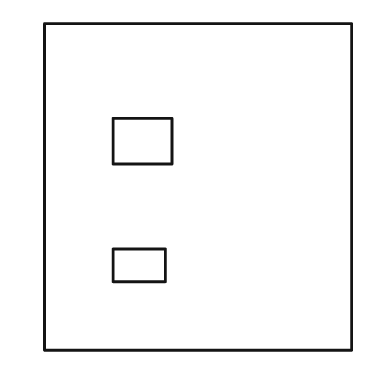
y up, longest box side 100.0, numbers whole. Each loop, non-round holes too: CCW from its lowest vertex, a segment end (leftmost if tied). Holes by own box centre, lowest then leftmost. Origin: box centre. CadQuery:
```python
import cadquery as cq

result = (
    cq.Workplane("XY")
    .moveTo(-47.0, -50.0)
    .lineTo(47.0, -50.0)
    .lineTo(47.0, 50.0)
    .lineTo(-47.0, 50.0)
    .close()
    .moveTo(-26.0, -29.0)
    .lineTo(-10.0, -29.0)
    .lineTo(-10.0, -19.0)
    .lineTo(-26.0, -19.0)
    .close()
    .moveTo(-26.0, 7.0)
    .lineTo(-8.0, 7.0)
    .lineTo(-8.0, 21.0)
    .lineTo(-26.0, 21.0)
    .close()
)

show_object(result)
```